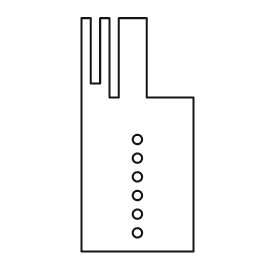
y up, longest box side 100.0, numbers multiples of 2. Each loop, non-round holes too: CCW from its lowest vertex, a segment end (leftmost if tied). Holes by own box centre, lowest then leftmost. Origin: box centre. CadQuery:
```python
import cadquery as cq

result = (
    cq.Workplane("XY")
    .moveTo(-24.0, -50.0)
    .lineTo(24.0, -50.0)
    .lineTo(24.0, 16.0)
    .lineTo(4.0, 16.0)
    .lineTo(4.0, 50.0)
    .lineTo(-8.0, 50.0)
    .lineTo(-8.0, 16.0)
    .lineTo(-12.0, 16.0)
    .lineTo(-12.0, 50.0)
    .lineTo(-16.0, 50.0)
    .lineTo(-16.0, 22.0)
    .lineTo(-20.0, 22.0)
    .lineTo(-20.0, 50.0)
    .lineTo(-24.0, 50.0)
    .close()
    .moveTo(0.0, -42.0)
    .circle(2.0)
    .moveTo(0.0, -34.0)
    .circle(2.0)
    .moveTo(0.0, -26.0)
    .circle(2.0)
    .moveTo(0.0, -18.0)
    .circle(2.0)
    .moveTo(0.0, -10.0)
    .circle(2.0)
    .moveTo(0.0, -2.0)
    .circle(2.0)
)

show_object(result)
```